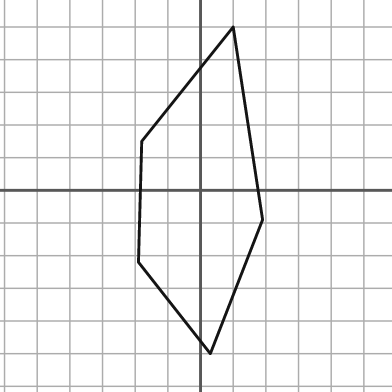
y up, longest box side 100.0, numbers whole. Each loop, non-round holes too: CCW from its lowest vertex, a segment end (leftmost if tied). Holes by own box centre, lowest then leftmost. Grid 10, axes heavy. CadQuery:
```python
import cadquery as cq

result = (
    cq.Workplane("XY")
    .moveTo(3.0, -50.0)
    .lineTo(19.0, -9.0)
    .lineTo(10.0, 50.0)
    .lineTo(-18.0, 15.0)
    .lineTo(-19.0, -22.0)
    .close()
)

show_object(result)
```